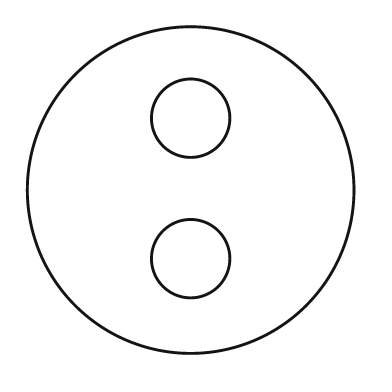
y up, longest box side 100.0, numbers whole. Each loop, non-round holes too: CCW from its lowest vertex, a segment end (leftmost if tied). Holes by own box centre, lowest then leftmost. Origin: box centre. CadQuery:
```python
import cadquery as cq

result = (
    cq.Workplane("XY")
    .moveTo(0.0, 0.0)
    .circle(50.0)
    .moveTo(0.0, -21.0)
    .circle(12.0)
    .moveTo(0.0, 22.0)
    .circle(12.0)
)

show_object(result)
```